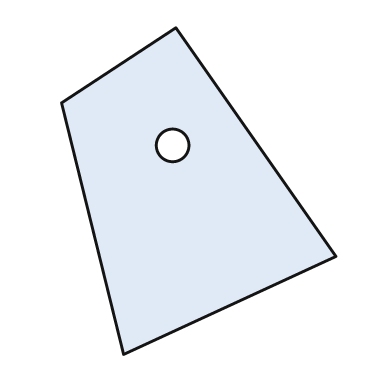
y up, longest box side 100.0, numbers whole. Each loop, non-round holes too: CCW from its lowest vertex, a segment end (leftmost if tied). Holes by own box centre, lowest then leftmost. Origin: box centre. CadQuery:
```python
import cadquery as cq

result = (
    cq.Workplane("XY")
    .moveTo(-23.0, -50.0)
    .lineTo(42.0, -20.0)
    .lineTo(-7.0, 50.0)
    .lineTo(-42.0, 27.0)
    .close()
    .moveTo(-8.0, 14.0)
    .circle(5.0)
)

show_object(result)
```